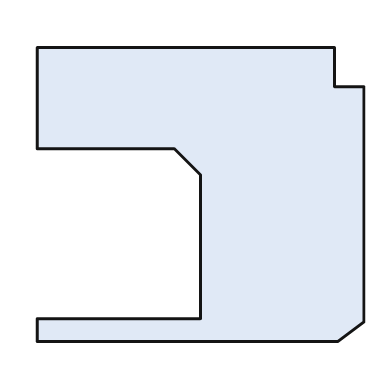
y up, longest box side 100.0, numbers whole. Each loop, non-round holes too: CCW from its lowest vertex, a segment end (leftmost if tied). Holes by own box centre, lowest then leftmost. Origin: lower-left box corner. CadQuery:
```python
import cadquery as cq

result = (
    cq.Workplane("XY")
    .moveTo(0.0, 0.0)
    .lineTo(92.0, 0.0)
    .lineTo(100.0, 6.0)
    .lineTo(100.0, 78.0)
    .lineTo(91.0, 78.0)
    .lineTo(91.0, 90.0)
    .lineTo(0.0, 90.0)
    .lineTo(0.0, 59.0)
    .lineTo(42.0, 59.0)
    .lineTo(50.0, 51.0)
    .lineTo(50.0, 7.0)
    .lineTo(0.0, 7.0)
    .close()
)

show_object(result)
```